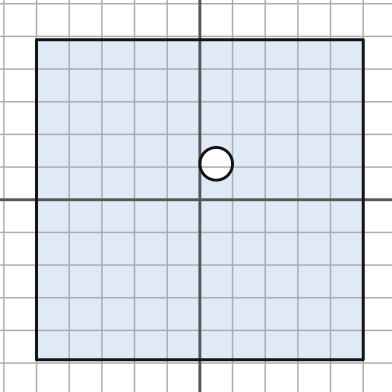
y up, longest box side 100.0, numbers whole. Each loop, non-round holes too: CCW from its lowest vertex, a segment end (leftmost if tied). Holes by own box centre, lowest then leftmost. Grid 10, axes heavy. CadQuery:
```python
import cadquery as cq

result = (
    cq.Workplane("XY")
    .moveTo(-50.0, -49.0)
    .lineTo(50.0, -49.0)
    .lineTo(50.0, 49.0)
    .lineTo(-50.0, 49.0)
    .close()
    .moveTo(5.0, 11.0)
    .circle(5.0)
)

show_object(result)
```